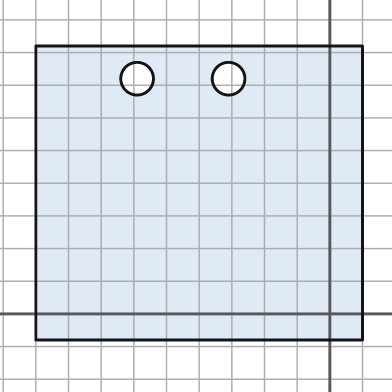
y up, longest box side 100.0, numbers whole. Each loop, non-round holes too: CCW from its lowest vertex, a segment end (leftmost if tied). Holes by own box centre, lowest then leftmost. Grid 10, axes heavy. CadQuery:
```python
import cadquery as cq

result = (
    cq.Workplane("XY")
    .moveTo(-90.0, -8.0)
    .lineTo(10.0, -8.0)
    .lineTo(10.0, 82.0)
    .lineTo(-90.0, 82.0)
    .close()
    .moveTo(-59.0, 72.0)
    .circle(5.0)
    .moveTo(-31.0, 72.0)
    .circle(5.0)
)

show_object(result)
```